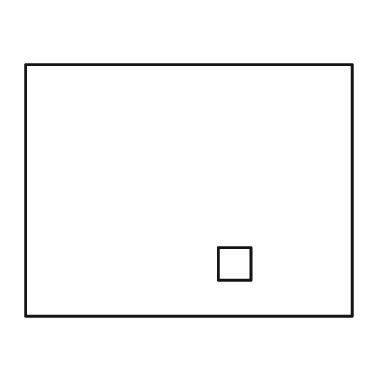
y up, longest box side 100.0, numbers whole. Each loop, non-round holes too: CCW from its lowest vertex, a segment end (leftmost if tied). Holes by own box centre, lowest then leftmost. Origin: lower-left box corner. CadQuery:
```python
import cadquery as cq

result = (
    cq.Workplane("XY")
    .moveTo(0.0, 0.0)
    .lineTo(100.0, 0.0)
    .lineTo(100.0, 77.0)
    .lineTo(0.0, 77.0)
    .close()
    .moveTo(59.0, 11.0)
    .lineTo(69.0, 11.0)
    .lineTo(69.0, 21.0)
    .lineTo(59.0, 21.0)
    .close()
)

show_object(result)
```